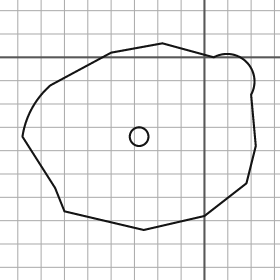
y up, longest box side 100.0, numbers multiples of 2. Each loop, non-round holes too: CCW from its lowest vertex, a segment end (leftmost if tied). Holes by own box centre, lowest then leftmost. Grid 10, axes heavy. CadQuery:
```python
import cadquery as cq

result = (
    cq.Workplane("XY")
    .moveTo(-26.0, -74.0)
    .lineTo(0.0, -68.0)
    .lineTo(18.0, -54.0)
    .lineTo(22.0, -38.0)
    .lineTo(20.0, -16.0)
    .threePointArc((18.0, -2.0), (4.0, 0.0))
    .lineTo(-18.0, 6.0)
    .lineTo(-40.0, 2.0)
    .lineTo(-66.0, -12.0)
    .threePointArc((-74.0, -22.0), (-78.0, -34.0))
    .lineTo(-64.0, -56.0)
    .lineTo(-60.0, -66.0)
    .close()
    .moveTo(-28.0, -34.0)
    .circle(4.0)
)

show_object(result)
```